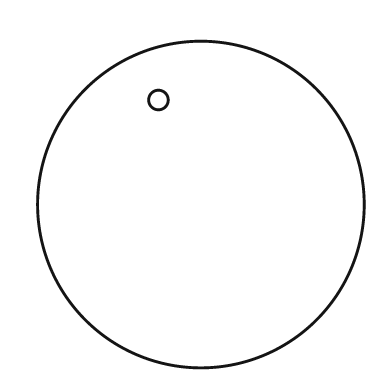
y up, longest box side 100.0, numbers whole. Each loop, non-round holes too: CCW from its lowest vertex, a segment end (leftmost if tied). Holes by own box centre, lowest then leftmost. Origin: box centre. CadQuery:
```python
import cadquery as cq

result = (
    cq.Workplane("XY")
    .moveTo(0.0, 0.0)
    .circle(50.0)
    .moveTo(-13.0, 32.0)
    .circle(3.0)
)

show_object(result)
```